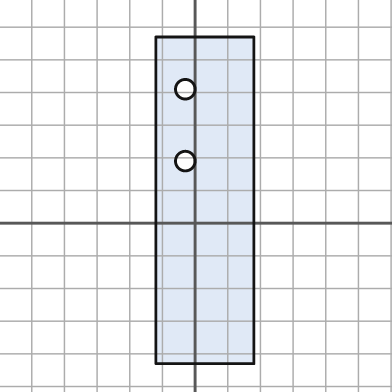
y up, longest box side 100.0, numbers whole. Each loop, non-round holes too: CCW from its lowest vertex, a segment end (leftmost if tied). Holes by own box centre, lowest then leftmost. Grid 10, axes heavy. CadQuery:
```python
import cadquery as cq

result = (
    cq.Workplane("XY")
    .moveTo(-12.0, -43.0)
    .lineTo(18.0, -43.0)
    .lineTo(18.0, 57.0)
    .lineTo(-12.0, 57.0)
    .close()
    .moveTo(-3.0, 19.0)
    .circle(3.0)
    .moveTo(-3.0, 41.0)
    .circle(3.0)
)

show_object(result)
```